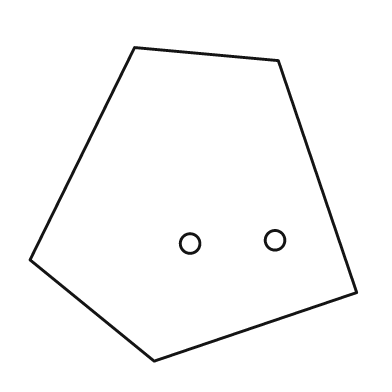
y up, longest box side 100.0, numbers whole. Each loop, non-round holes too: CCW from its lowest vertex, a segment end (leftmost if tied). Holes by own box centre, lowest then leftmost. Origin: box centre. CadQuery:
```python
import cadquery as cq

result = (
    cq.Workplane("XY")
    .moveTo(-12.0, -48.0)
    .lineTo(50.0, -27.0)
    .lineTo(26.0, 44.0)
    .lineTo(-18.0, 48.0)
    .lineTo(-50.0, -17.0)
    .close()
    .moveTo(-1.0, -12.0)
    .circle(3.0)
    .moveTo(25.0, -11.0)
    .circle(3.0)
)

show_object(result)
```